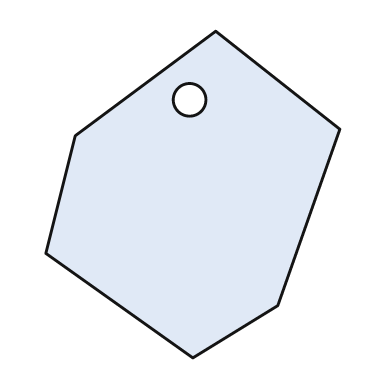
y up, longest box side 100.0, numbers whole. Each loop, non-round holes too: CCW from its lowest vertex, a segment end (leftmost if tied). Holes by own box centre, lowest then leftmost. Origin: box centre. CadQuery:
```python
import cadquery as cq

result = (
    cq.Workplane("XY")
    .moveTo(0.0, -50.0)
    .lineTo(26.0, -34.0)
    .lineTo(45.0, 20.0)
    .lineTo(7.0, 50.0)
    .lineTo(-36.0, 18.0)
    .lineTo(-45.0, -18.0)
    .close()
    .moveTo(-1.0, 29.0)
    .circle(5.0)
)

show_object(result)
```